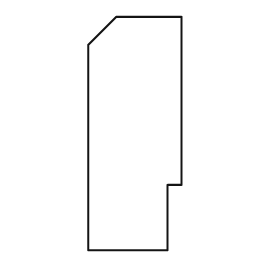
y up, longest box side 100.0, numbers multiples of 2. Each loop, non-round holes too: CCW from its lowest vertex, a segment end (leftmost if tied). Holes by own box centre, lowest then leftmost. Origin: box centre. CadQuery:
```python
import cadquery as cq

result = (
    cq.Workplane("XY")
    .moveTo(-20.0, -50.0)
    .lineTo(14.0, -50.0)
    .lineTo(14.0, -22.0)
    .lineTo(20.0, -22.0)
    .lineTo(20.0, 50.0)
    .lineTo(-8.0, 50.0)
    .lineTo(-20.0, 38.0)
    .close()
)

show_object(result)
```